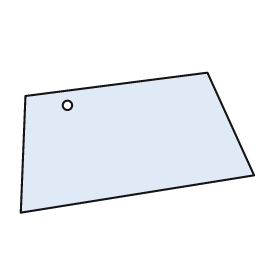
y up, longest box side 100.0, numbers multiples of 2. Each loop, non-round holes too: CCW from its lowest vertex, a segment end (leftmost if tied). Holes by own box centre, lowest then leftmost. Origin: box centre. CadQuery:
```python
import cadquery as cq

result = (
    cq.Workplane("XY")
    .moveTo(-50.0, -30.0)
    .lineTo(50.0, -14.0)
    .lineTo(30.0, 30.0)
    .lineTo(-48.0, 20.0)
    .close()
    .moveTo(-30.0, 16.0)
    .circle(2.0)
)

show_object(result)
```